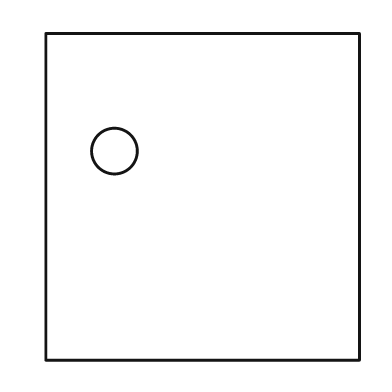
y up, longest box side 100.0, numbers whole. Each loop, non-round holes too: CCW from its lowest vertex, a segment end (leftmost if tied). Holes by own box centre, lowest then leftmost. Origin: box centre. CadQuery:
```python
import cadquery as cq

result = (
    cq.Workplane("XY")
    .moveTo(-48.0, -50.0)
    .lineTo(48.0, -50.0)
    .lineTo(48.0, 50.0)
    .lineTo(-48.0, 50.0)
    .close()
    .moveTo(-27.0, 14.0)
    .circle(7.0)
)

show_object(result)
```